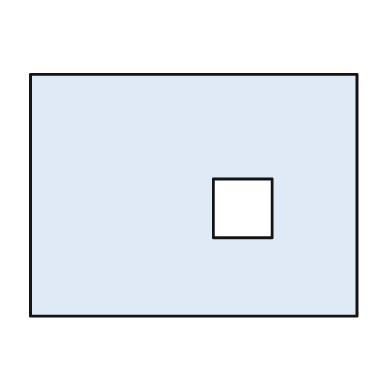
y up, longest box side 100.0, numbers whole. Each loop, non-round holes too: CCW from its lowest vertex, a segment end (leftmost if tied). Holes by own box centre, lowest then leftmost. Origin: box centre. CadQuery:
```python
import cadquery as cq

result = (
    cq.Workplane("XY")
    .moveTo(-50.0, -37.0)
    .lineTo(50.0, -37.0)
    .lineTo(50.0, 37.0)
    .lineTo(-50.0, 37.0)
    .close()
    .moveTo(6.0, -13.0)
    .lineTo(24.0, -13.0)
    .lineTo(24.0, 5.0)
    .lineTo(6.0, 5.0)
    .close()
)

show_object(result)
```